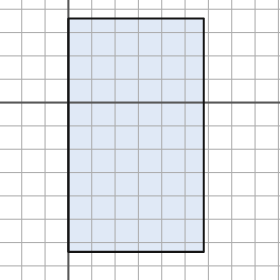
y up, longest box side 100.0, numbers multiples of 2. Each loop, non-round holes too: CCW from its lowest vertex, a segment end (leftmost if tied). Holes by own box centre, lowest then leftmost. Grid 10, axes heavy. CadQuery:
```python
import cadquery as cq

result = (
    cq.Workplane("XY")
    .moveTo(0.0, -64.0)
    .lineTo(58.0, -64.0)
    .lineTo(58.0, 36.0)
    .lineTo(0.0, 36.0)
    .close()
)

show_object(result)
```